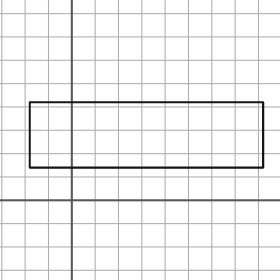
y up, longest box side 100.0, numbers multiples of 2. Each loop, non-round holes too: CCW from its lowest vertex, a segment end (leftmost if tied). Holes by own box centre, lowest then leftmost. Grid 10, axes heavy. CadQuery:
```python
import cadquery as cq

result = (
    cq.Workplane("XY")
    .moveTo(-18.0, 14.0)
    .lineTo(82.0, 14.0)
    .lineTo(82.0, 42.0)
    .lineTo(-18.0, 42.0)
    .close()
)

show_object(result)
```